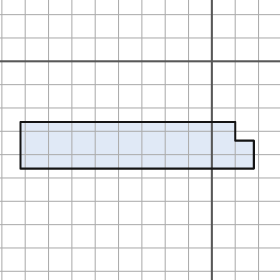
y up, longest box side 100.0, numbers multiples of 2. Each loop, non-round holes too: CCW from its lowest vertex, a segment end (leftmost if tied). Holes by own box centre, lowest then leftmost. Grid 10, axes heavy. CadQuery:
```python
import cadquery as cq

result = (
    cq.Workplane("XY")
    .moveTo(-82.0, -46.0)
    .lineTo(18.0, -46.0)
    .lineTo(18.0, -34.0)
    .lineTo(10.0, -34.0)
    .lineTo(10.0, -26.0)
    .lineTo(-82.0, -26.0)
    .close()
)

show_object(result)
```